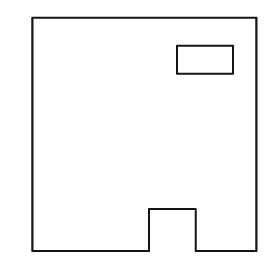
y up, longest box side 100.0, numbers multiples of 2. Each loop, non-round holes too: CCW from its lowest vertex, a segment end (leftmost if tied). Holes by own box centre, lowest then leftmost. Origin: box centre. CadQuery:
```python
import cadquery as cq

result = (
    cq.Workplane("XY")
    .moveTo(-48.0, -50.0)
    .lineTo(2.0, -50.0)
    .lineTo(2.0, -32.0)
    .lineTo(22.0, -32.0)
    .lineTo(22.0, -50.0)
    .lineTo(48.0, -50.0)
    .lineTo(48.0, 50.0)
    .lineTo(-48.0, 50.0)
    .close()
    .moveTo(14.0, 26.0)
    .lineTo(38.0, 26.0)
    .lineTo(38.0, 38.0)
    .lineTo(14.0, 38.0)
    .close()
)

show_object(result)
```